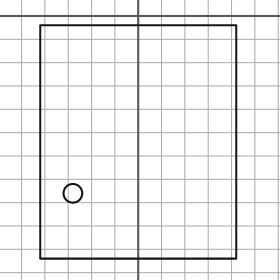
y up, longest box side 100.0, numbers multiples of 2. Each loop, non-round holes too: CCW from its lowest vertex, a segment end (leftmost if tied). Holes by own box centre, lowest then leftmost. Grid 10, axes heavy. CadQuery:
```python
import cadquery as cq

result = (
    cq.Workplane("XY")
    .moveTo(-42.0, -104.0)
    .lineTo(42.0, -104.0)
    .lineTo(42.0, -4.0)
    .lineTo(-42.0, -4.0)
    .close()
    .moveTo(-28.0, -76.0)
    .circle(4.0)
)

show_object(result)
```